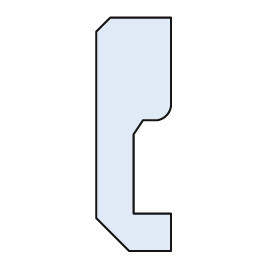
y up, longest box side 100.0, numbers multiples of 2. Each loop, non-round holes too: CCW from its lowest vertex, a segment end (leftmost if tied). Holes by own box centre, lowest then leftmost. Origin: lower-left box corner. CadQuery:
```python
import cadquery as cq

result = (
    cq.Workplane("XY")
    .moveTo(14.0, 0.0)
    .lineTo(32.0, 0.0)
    .lineTo(32.0, 16.0)
    .lineTo(16.0, 16.0)
    .lineTo(16.0, 50.0)
    .lineTo(20.0, 56.0)
    .lineTo(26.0, 56.0)
    .threePointArc((30.0, 58.0), (32.0, 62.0))
    .lineTo(32.0, 100.0)
    .lineTo(6.0, 100.0)
    .lineTo(0.0, 94.0)
    .lineTo(0.0, 14.0)
    .close()
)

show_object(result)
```